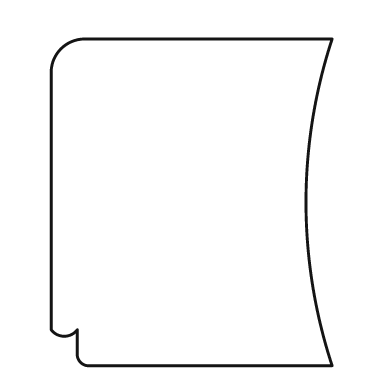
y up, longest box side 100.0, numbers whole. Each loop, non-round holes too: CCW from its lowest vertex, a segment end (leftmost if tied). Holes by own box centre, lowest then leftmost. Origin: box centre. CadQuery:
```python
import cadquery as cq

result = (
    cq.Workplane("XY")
    .moveTo(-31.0, -50.0)
    .lineTo(43.0, -50.0)
    .threePointArc((35.0, 0.0), (43.0, 50.0))
    .lineTo(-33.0, 50.0)
    .threePointArc((-40.0, 47.0), (-43.0, 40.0))
    .lineTo(-43.0, -39.0)
    .threePointArc((-39.0, -41.0), (-35.0, -39.0))
    .lineTo(-35.0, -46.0)
    .threePointArc((-34.0, -49.0), (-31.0, -50.0))
    .close()
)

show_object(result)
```